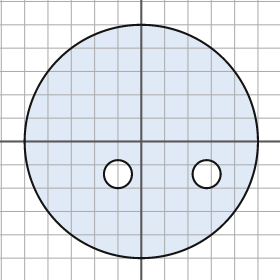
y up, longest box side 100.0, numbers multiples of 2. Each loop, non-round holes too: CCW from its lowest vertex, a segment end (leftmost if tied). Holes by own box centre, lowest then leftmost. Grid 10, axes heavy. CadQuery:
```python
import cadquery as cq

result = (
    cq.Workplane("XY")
    .moveTo(0.0, 0.0)
    .circle(50.0)
    .moveTo(-10.0, -14.0)
    .circle(6.0)
    .moveTo(28.0, -14.0)
    .circle(6.0)
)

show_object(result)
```